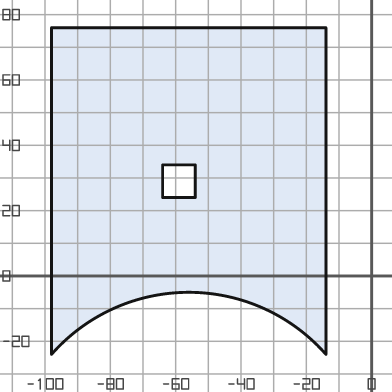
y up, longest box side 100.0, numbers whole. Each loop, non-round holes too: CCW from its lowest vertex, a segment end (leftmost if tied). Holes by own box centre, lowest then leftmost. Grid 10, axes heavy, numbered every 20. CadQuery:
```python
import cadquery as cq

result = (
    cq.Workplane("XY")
    .moveTo(-98.0, -24.0)
    .threePointArc((-56.0, -5.0), (-14.0, -24.0))
    .lineTo(-14.0, 76.0)
    .lineTo(-98.0, 76.0)
    .close()
    .moveTo(-64.0, 24.0)
    .lineTo(-54.0, 24.0)
    .lineTo(-54.0, 34.0)
    .lineTo(-64.0, 34.0)
    .close()
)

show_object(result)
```